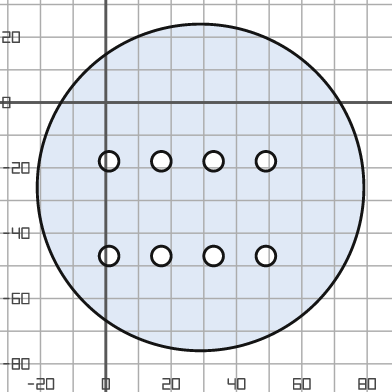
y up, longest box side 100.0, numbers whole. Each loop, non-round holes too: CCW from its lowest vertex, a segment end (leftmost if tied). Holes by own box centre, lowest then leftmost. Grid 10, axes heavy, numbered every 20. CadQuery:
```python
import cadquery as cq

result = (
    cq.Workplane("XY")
    .moveTo(29.0, -26.0)
    .circle(50.0)
    .moveTo(1.0, -47.0)
    .circle(3.0)
    .moveTo(17.0, -47.0)
    .circle(3.0)
    .moveTo(33.0, -47.0)
    .circle(3.0)
    .moveTo(49.0, -47.0)
    .circle(3.0)
    .moveTo(1.0, -18.0)
    .circle(3.0)
    .moveTo(17.0, -18.0)
    .circle(3.0)
    .moveTo(33.0, -18.0)
    .circle(3.0)
    .moveTo(49.0, -18.0)
    .circle(3.0)
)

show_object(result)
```